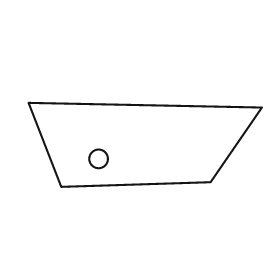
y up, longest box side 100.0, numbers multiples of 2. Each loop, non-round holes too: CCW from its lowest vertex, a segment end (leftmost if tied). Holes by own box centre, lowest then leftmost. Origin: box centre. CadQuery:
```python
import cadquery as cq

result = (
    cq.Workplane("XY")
    .moveTo(-36.0, -18.0)
    .lineTo(28.0, -16.0)
    .lineTo(50.0, 16.0)
    .lineTo(-50.0, 18.0)
    .close()
    .moveTo(-20.0, -6.0)
    .circle(4.0)
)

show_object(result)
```